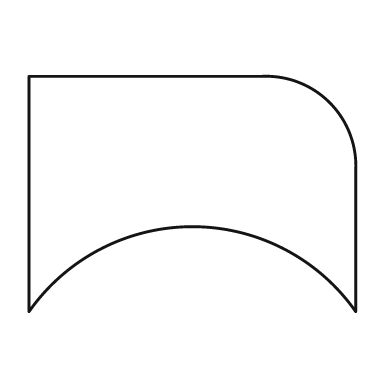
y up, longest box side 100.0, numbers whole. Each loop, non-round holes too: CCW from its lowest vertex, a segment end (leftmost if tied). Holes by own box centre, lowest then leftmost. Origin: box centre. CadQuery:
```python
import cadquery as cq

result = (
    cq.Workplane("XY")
    .moveTo(-50.0, -36.0)
    .threePointArc((0.0, -10.0), (50.0, -36.0))
    .lineTo(50.0, 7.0)
    .threePointArc((42.0, 28.0), (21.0, 36.0))
    .lineTo(-50.0, 36.0)
    .close()
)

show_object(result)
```